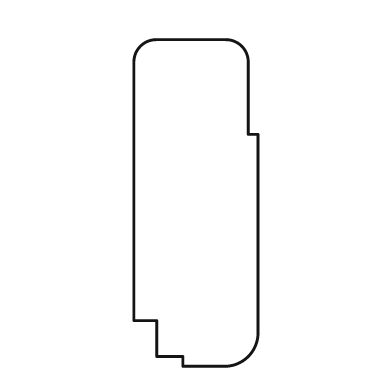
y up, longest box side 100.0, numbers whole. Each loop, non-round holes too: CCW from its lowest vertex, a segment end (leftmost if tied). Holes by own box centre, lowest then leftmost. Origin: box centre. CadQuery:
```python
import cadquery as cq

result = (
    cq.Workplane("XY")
    .moveTo(-4.0, -50.0)
    .lineTo(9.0, -50.0)
    .threePointArc((16.0, -47.0), (19.0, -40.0))
    .lineTo(19.0, 21.0)
    .lineTo(16.0, 21.0)
    .lineTo(16.0, 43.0)
    .threePointArc((14.0, 48.0), (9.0, 50.0))
    .lineTo(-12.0, 50.0)
    .threePointArc((-17.0, 48.0), (-19.0, 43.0))
    .lineTo(-19.0, -36.0)
    .lineTo(-12.0, -36.0)
    .lineTo(-12.0, -47.0)
    .lineTo(-4.0, -47.0)
    .close()
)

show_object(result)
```